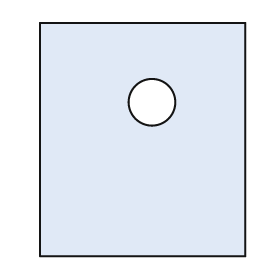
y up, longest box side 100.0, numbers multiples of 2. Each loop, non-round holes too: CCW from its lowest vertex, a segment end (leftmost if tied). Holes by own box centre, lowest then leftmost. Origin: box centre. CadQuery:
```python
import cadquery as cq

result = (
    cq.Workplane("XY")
    .moveTo(-44.0, -50.0)
    .lineTo(44.0, -50.0)
    .lineTo(44.0, 50.0)
    .lineTo(-44.0, 50.0)
    .close()
    .moveTo(4.0, 16.0)
    .circle(10.0)
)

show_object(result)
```